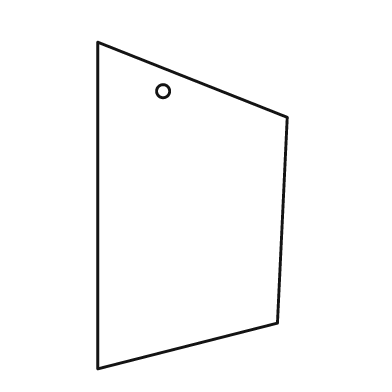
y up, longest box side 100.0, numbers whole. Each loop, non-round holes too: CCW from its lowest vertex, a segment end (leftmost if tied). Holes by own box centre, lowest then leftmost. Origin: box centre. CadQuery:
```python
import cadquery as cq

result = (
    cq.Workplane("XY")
    .moveTo(-29.0, -50.0)
    .lineTo(26.0, -36.0)
    .lineTo(29.0, 27.0)
    .lineTo(-29.0, 50.0)
    .close()
    .moveTo(-9.0, 35.0)
    .circle(2.0)
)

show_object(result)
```